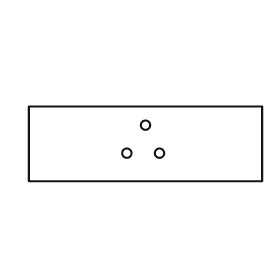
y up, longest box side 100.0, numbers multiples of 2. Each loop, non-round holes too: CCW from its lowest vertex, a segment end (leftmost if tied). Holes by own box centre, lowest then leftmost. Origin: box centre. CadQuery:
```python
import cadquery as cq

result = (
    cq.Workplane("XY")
    .moveTo(-50.0, -16.0)
    .lineTo(50.0, -16.0)
    .lineTo(50.0, 16.0)
    .lineTo(-50.0, 16.0)
    .close()
    .moveTo(-8.0, -4.0)
    .circle(2.0)
    .moveTo(6.0, -4.0)
    .circle(2.0)
    .moveTo(0.0, 8.0)
    .circle(2.0)
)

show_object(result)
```